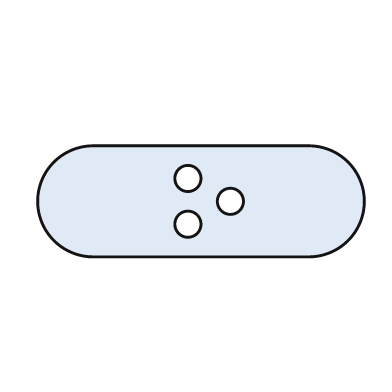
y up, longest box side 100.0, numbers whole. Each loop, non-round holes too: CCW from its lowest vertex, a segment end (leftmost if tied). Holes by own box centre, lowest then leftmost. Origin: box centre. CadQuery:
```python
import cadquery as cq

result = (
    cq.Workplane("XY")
    .moveTo(-33.0, -17.0)
    .lineTo(33.0, -17.0)
    .threePointArc((50.0, 0.0), (33.0, 17.0))
    .lineTo(-33.0, 17.0)
    .threePointArc((-50.0, 0.0), (-33.0, -17.0))
    .close()
    .moveTo(-4.0, -7.0)
    .circle(4.0)
    .moveTo(9.0, 0.0)
    .circle(4.0)
    .moveTo(-4.0, 7.0)
    .circle(4.0)
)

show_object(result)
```